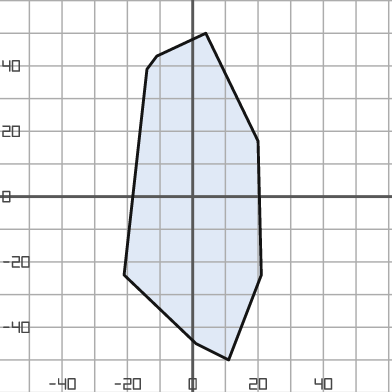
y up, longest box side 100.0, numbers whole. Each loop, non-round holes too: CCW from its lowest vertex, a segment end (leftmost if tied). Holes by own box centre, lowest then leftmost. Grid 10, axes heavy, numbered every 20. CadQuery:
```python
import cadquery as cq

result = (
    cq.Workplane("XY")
    .moveTo(11.0, -50.0)
    .lineTo(21.0, -24.0)
    .lineTo(20.0, 17.0)
    .lineTo(4.0, 50.0)
    .lineTo(-11.0, 43.0)
    .lineTo(-14.0, 39.0)
    .lineTo(-21.0, -24.0)
    .lineTo(1.0, -45.0)
    .close()
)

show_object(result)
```